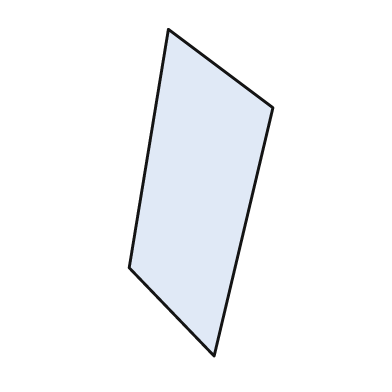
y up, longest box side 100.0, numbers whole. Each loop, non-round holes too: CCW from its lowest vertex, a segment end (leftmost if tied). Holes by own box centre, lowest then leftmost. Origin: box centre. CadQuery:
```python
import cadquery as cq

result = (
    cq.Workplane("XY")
    .moveTo(4.0, -50.0)
    .lineTo(22.0, 26.0)
    .lineTo(-10.0, 50.0)
    .lineTo(-22.0, -23.0)
    .close()
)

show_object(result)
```